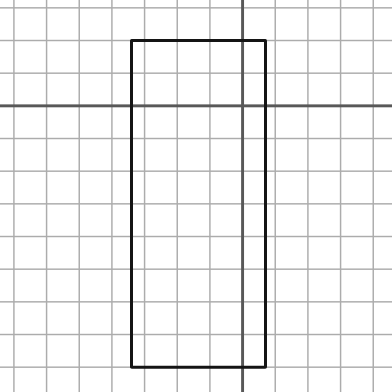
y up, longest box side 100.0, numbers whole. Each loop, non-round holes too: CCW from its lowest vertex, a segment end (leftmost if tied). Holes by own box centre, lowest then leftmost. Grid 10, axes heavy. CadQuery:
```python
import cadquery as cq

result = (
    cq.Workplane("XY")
    .moveTo(-34.0, -80.0)
    .lineTo(7.0, -80.0)
    .lineTo(7.0, 20.0)
    .lineTo(-34.0, 20.0)
    .close()
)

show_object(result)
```